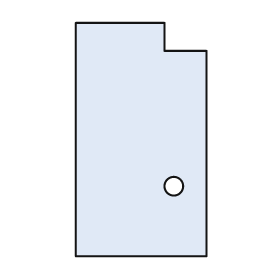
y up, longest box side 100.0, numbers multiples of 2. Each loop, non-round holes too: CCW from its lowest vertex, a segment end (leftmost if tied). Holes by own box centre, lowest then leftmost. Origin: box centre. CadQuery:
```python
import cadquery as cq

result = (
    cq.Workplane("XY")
    .moveTo(-28.0, -50.0)
    .lineTo(28.0, -50.0)
    .lineTo(28.0, 38.0)
    .lineTo(10.0, 38.0)
    .lineTo(10.0, 50.0)
    .lineTo(-28.0, 50.0)
    .close()
    .moveTo(14.0, -20.0)
    .circle(4.0)
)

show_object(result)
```